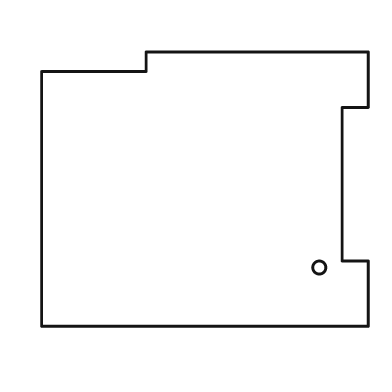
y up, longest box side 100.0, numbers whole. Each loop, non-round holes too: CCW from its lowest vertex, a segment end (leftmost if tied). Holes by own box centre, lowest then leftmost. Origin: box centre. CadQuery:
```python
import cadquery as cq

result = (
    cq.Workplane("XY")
    .moveTo(-50.0, -42.0)
    .lineTo(50.0, -42.0)
    .lineTo(50.0, -22.0)
    .lineTo(42.0, -22.0)
    .lineTo(42.0, 25.0)
    .lineTo(50.0, 25.0)
    .lineTo(50.0, 42.0)
    .lineTo(-18.0, 42.0)
    .lineTo(-18.0, 36.0)
    .lineTo(-50.0, 36.0)
    .close()
    .moveTo(35.0, -24.0)
    .circle(2.0)
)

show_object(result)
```